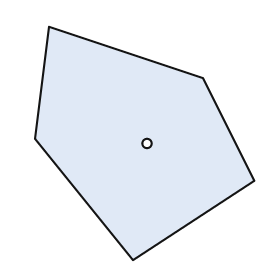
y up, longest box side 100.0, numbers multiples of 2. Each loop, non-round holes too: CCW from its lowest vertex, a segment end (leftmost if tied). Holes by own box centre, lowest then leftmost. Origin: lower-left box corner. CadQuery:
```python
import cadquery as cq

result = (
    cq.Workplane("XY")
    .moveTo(42.0, 0.0)
    .lineTo(94.0, 34.0)
    .lineTo(72.0, 78.0)
    .lineTo(6.0, 100.0)
    .lineTo(0.0, 52.0)
    .close()
    .moveTo(48.0, 50.0)
    .circle(2.0)
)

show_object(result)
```